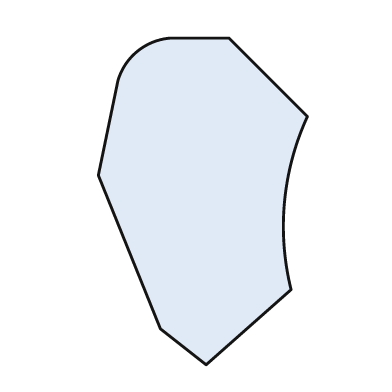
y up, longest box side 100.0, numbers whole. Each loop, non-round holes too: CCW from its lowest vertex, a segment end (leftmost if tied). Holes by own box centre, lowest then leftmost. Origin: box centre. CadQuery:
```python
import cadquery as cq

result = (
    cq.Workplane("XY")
    .moveTo(1.0, -50.0)
    .lineTo(27.0, -27.0)
    .threePointArc((25.0, 0.0), (32.0, 26.0))
    .lineTo(8.0, 50.0)
    .lineTo(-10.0, 50.0)
    .threePointArc((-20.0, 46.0), (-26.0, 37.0))
    .lineTo(-32.0, 8.0)
    .lineTo(-13.0, -39.0)
    .close()
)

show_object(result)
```